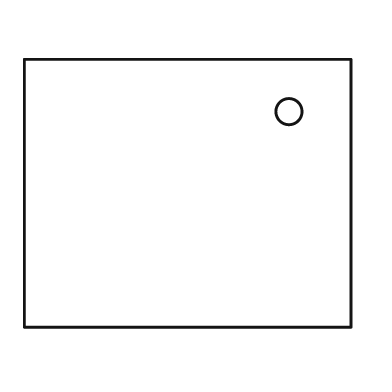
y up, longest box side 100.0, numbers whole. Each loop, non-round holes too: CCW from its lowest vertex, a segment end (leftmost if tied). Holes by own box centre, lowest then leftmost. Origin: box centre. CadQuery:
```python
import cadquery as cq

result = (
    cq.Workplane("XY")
    .moveTo(-50.0, -41.0)
    .lineTo(50.0, -41.0)
    .lineTo(50.0, 41.0)
    .lineTo(-50.0, 41.0)
    .close()
    .moveTo(31.0, 25.0)
    .circle(4.0)
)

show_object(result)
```